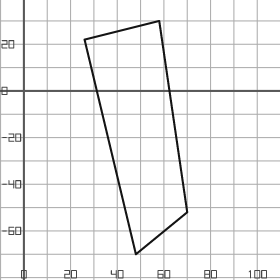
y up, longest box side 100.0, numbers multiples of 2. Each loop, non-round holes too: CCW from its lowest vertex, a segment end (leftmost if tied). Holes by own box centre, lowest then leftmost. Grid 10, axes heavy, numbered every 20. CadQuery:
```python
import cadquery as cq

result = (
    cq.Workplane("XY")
    .moveTo(48.0, -70.0)
    .lineTo(70.0, -52.0)
    .lineTo(58.0, 30.0)
    .lineTo(26.0, 22.0)
    .close()
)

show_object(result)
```